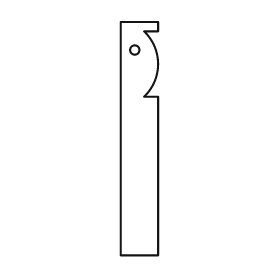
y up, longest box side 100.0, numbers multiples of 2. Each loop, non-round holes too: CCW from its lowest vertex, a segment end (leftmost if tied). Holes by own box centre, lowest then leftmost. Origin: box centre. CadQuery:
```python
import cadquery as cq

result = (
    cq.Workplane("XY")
    .moveTo(-8.0, -50.0)
    .lineTo(8.0, -50.0)
    .lineTo(8.0, 18.0)
    .lineTo(2.0, 18.0)
    .threePointArc((8.0, 32.0), (2.0, 46.0))
    .lineTo(8.0, 46.0)
    .lineTo(8.0, 50.0)
    .lineTo(-8.0, 50.0)
    .close()
    .moveTo(-2.0, 38.0)
    .circle(2.0)
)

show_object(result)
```